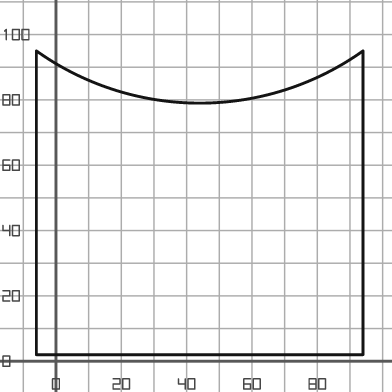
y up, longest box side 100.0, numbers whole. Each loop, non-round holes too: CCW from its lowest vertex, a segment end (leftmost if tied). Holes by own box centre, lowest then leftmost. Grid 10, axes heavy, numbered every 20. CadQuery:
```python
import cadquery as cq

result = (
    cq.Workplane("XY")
    .moveTo(-6.0, 2.0)
    .lineTo(94.0, 2.0)
    .lineTo(94.0, 95.0)
    .threePointArc((44.0, 79.0), (-6.0, 95.0))
    .close()
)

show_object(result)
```